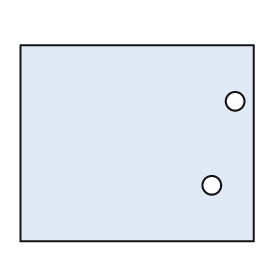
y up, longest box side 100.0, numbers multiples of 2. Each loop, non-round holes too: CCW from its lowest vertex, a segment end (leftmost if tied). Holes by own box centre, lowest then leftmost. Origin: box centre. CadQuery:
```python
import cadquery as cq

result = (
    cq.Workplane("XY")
    .moveTo(-50.0, -42.0)
    .lineTo(50.0, -42.0)
    .lineTo(50.0, 42.0)
    .lineTo(-50.0, 42.0)
    .close()
    .moveTo(32.0, -18.0)
    .circle(4.0)
    .moveTo(42.0, 18.0)
    .circle(4.0)
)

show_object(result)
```